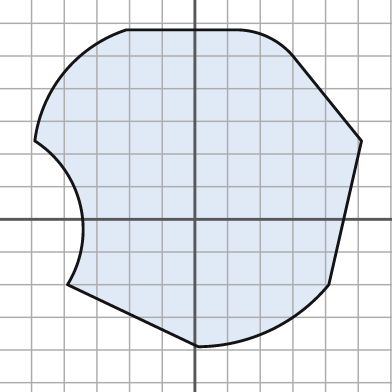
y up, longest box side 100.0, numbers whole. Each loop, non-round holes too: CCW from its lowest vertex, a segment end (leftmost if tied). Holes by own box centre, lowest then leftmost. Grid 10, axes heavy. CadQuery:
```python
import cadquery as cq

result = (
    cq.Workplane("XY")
    .moveTo(1.0, -39.0)
    .threePointArc((23.0, -34.0), (41.0, -20.0))
    .lineTo(51.0, 24.0)
    .lineTo(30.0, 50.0)
    .threePointArc((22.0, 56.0), (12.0, 58.0))
    .lineTo(-21.0, 58.0)
    .threePointArc((-40.0, 45.0), (-49.0, 24.0))
    .threePointArc((-35.0, 4.0), (-39.0, -20.0))
    .close()
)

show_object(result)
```